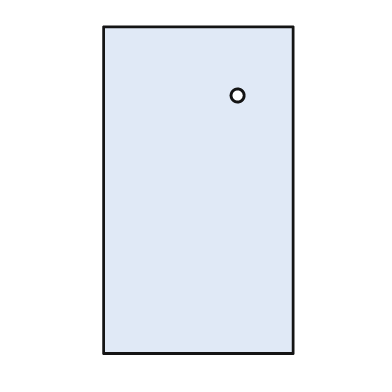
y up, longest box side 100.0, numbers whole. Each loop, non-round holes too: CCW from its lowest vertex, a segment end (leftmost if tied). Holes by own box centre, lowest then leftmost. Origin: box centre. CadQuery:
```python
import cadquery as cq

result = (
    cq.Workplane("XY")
    .moveTo(-29.0, -50.0)
    .lineTo(29.0, -50.0)
    .lineTo(29.0, 50.0)
    .lineTo(-29.0, 50.0)
    .close()
    .moveTo(12.0, 29.0)
    .circle(2.0)
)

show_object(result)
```